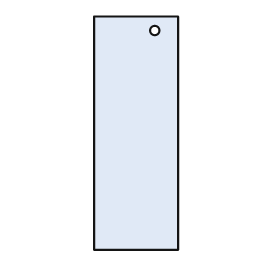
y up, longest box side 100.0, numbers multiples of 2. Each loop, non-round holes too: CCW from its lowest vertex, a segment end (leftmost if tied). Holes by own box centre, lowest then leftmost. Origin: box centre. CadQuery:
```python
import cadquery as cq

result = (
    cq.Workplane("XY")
    .moveTo(-18.0, -50.0)
    .lineTo(18.0, -50.0)
    .lineTo(18.0, 50.0)
    .lineTo(-18.0, 50.0)
    .close()
    .moveTo(8.0, 44.0)
    .circle(2.0)
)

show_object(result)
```